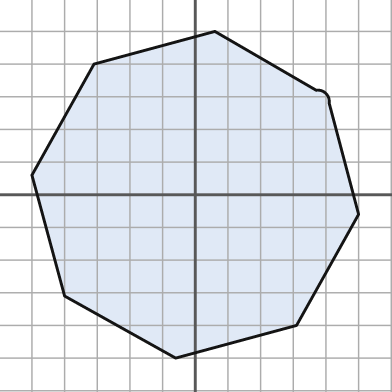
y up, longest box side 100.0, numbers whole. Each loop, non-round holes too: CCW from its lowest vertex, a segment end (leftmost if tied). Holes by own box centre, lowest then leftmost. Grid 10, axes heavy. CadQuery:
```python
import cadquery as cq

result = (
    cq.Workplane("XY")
    .moveTo(-6.0, -50.0)
    .lineTo(31.0, -40.0)
    .lineTo(50.0, -6.0)
    .lineTo(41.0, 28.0)
    .threePointArc((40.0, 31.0), (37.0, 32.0))
    .lineTo(6.0, 50.0)
    .lineTo(-31.0, 40.0)
    .lineTo(-50.0, 6.0)
    .lineTo(-40.0, -31.0)
    .close()
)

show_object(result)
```